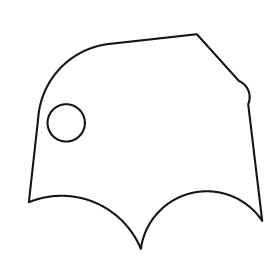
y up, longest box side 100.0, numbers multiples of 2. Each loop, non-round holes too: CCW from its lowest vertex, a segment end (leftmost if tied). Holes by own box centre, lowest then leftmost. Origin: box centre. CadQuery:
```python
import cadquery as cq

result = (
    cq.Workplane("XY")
    .moveTo(-2.0, -46.0)
    .threePointArc((20.0, -22.0), (50.0, -34.0))
    .lineTo(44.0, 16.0)
    .threePointArc((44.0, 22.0), (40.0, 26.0))
    .lineTo(22.0, 46.0)
    .lineTo(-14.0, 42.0)
    .threePointArc((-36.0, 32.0), (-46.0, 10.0))
    .lineTo(-50.0, -26.0)
    .threePointArc((-22.0, -26.0), (-2.0, -46.0))
    .close()
    .moveTo(-34.0, 8.0)
    .circle(8.0)
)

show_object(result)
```